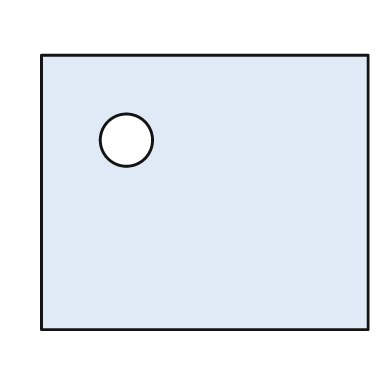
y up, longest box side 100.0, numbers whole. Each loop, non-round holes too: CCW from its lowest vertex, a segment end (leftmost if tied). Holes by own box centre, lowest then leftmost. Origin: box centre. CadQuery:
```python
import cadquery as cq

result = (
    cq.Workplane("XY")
    .moveTo(-50.0, -42.0)
    .lineTo(50.0, -42.0)
    .lineTo(50.0, 42.0)
    .lineTo(-50.0, 42.0)
    .close()
    .moveTo(-24.0, 16.0)
    .circle(8.0)
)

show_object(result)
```